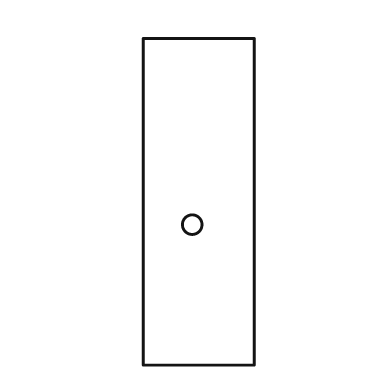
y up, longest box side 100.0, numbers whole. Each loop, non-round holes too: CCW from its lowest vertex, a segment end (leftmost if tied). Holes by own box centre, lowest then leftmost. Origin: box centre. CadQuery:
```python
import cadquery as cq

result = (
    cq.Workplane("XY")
    .moveTo(-17.0, -50.0)
    .lineTo(17.0, -50.0)
    .lineTo(17.0, 50.0)
    .lineTo(-17.0, 50.0)
    .close()
    .moveTo(-2.0, -7.0)
    .circle(3.0)
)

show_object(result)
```